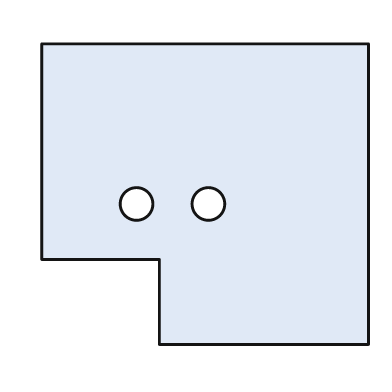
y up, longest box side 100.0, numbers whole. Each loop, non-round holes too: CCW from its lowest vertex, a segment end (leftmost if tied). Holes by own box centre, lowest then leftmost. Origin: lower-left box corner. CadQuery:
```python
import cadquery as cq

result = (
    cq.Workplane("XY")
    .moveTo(36.0, 0.0)
    .lineTo(100.0, 0.0)
    .lineTo(100.0, 92.0)
    .lineTo(0.0, 92.0)
    .lineTo(0.0, 26.0)
    .lineTo(36.0, 26.0)
    .close()
    .moveTo(29.0, 43.0)
    .circle(5.0)
    .moveTo(51.0, 43.0)
    .circle(5.0)
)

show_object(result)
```